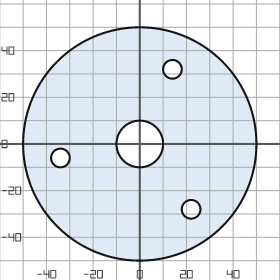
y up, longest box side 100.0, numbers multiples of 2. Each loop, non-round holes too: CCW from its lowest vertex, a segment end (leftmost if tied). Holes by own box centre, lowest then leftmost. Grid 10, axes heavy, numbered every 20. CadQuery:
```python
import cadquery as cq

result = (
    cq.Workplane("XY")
    .moveTo(0.0, 0.0)
    .circle(50.0)
    .moveTo(22.0, -28.0)
    .circle(4.0)
    .moveTo(-34.0, -6.0)
    .circle(4.0)
    .moveTo(0.0, 0.0)
    .circle(10.0)
    .moveTo(14.0, 32.0)
    .circle(4.0)
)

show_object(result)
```